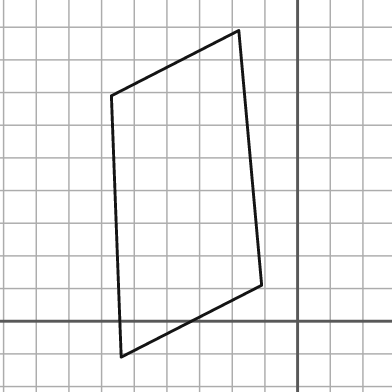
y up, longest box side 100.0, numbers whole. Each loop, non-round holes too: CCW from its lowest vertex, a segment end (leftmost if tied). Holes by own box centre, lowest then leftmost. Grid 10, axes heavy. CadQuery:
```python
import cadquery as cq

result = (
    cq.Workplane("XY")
    .moveTo(-54.0, -11.0)
    .lineTo(-11.0, 11.0)
    .lineTo(-18.0, 89.0)
    .lineTo(-57.0, 69.0)
    .close()
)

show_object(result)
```